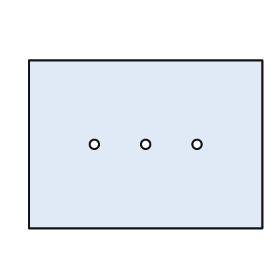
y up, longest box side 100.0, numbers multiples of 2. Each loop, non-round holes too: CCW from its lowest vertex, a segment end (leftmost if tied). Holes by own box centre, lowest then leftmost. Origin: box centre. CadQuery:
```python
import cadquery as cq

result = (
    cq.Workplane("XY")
    .moveTo(-50.0, -36.0)
    .lineTo(50.0, -36.0)
    .lineTo(50.0, 36.0)
    .lineTo(-50.0, 36.0)
    .close()
    .moveTo(-22.0, 0.0)
    .circle(2.0)
    .moveTo(0.0, 0.0)
    .circle(2.0)
    .moveTo(22.0, 0.0)
    .circle(2.0)
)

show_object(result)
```